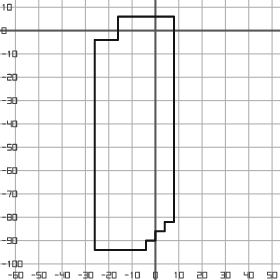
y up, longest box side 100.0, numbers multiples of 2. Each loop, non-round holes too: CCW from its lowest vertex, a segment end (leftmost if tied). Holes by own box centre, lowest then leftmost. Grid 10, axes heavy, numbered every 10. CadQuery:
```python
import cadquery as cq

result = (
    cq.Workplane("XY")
    .moveTo(-26.0, -94.0)
    .lineTo(-4.0, -94.0)
    .lineTo(-4.0, -90.0)
    .lineTo(0.0, -90.0)
    .lineTo(0.0, -86.0)
    .lineTo(4.0, -86.0)
    .lineTo(4.0, -82.0)
    .lineTo(8.0, -82.0)
    .lineTo(8.0, 6.0)
    .lineTo(-16.0, 6.0)
    .lineTo(-16.0, -4.0)
    .lineTo(-26.0, -4.0)
    .close()
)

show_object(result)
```